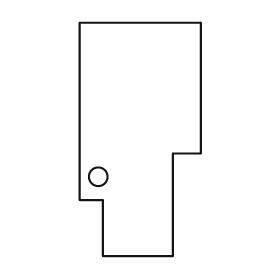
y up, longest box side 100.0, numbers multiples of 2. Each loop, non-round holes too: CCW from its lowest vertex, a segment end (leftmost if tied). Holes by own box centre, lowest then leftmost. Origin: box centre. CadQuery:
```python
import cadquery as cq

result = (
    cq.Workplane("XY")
    .moveTo(-16.0, -50.0)
    .lineTo(14.0, -50.0)
    .lineTo(14.0, -6.0)
    .lineTo(26.0, -6.0)
    .lineTo(26.0, 50.0)
    .lineTo(-26.0, 50.0)
    .lineTo(-26.0, -26.0)
    .lineTo(-16.0, -26.0)
    .close()
    .moveTo(-18.0, -16.0)
    .circle(4.0)
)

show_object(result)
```